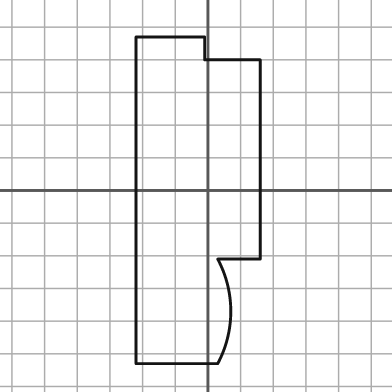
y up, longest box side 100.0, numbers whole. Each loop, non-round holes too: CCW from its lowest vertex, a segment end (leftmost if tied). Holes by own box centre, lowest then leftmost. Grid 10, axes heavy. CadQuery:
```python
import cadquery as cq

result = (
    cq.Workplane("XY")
    .moveTo(-22.0, -53.0)
    .lineTo(3.0, -53.0)
    .threePointArc((7.0, -37.0), (3.0, -21.0))
    .lineTo(16.0, -21.0)
    .lineTo(16.0, 40.0)
    .lineTo(-1.0, 40.0)
    .lineTo(-1.0, 47.0)
    .lineTo(-22.0, 47.0)
    .close()
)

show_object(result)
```